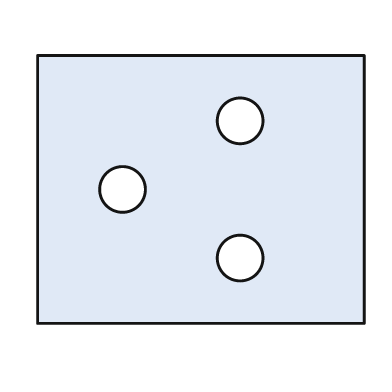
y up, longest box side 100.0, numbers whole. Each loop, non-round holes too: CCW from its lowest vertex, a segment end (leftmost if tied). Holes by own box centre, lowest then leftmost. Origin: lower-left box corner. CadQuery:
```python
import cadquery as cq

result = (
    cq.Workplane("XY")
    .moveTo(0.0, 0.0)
    .lineTo(100.0, 0.0)
    .lineTo(100.0, 82.0)
    .lineTo(0.0, 82.0)
    .close()
    .moveTo(62.0, 20.0)
    .circle(7.0)
    .moveTo(26.0, 41.0)
    .circle(7.0)
    .moveTo(62.0, 62.0)
    .circle(7.0)
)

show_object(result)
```